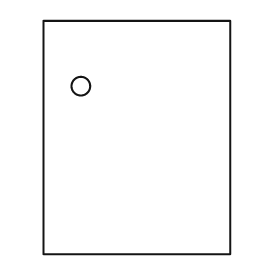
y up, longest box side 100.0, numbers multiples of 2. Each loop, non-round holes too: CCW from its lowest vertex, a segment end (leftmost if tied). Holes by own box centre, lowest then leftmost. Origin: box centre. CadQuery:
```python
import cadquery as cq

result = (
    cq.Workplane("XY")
    .moveTo(-40.0, -50.0)
    .lineTo(40.0, -50.0)
    .lineTo(40.0, 50.0)
    .lineTo(-40.0, 50.0)
    .close()
    .moveTo(-24.0, 22.0)
    .circle(4.0)
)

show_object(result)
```